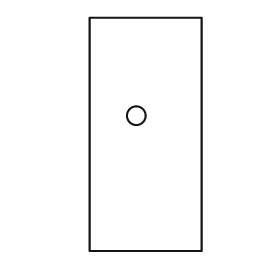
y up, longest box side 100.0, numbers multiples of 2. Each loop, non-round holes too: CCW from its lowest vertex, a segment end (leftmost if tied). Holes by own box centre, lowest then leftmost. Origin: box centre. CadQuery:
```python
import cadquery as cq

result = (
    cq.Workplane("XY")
    .moveTo(-24.0, -50.0)
    .lineTo(24.0, -50.0)
    .lineTo(24.0, 50.0)
    .lineTo(-24.0, 50.0)
    .close()
    .moveTo(-4.0, 8.0)
    .circle(4.0)
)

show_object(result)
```